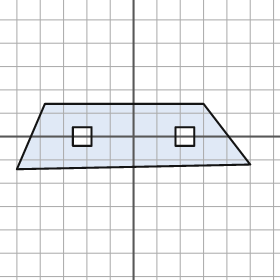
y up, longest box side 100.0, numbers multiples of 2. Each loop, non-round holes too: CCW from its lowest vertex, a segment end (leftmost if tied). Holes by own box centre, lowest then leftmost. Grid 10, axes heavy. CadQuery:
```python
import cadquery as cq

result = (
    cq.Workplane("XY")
    .moveTo(-50.0, -14.0)
    .lineTo(50.0, -12.0)
    .lineTo(30.0, 14.0)
    .lineTo(-38.0, 14.0)
    .close()
    .moveTo(-26.0, -4.0)
    .lineTo(-18.0, -4.0)
    .lineTo(-18.0, 4.0)
    .lineTo(-26.0, 4.0)
    .close()
    .moveTo(18.0, -4.0)
    .lineTo(26.0, -4.0)
    .lineTo(26.0, 4.0)
    .lineTo(18.0, 4.0)
    .close()
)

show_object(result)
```